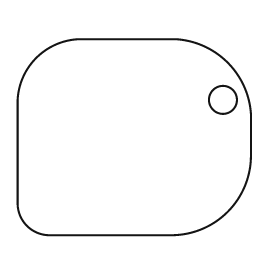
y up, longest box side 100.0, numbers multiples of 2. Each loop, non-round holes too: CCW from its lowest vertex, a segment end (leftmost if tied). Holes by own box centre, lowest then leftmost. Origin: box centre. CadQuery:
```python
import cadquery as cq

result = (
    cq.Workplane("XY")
    .moveTo(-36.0, -42.0)
    .lineTo(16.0, -42.0)
    .threePointArc((40.0, -32.0), (50.0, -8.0))
    .lineTo(50.0, 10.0)
    .threePointArc((40.0, 32.0), (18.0, 42.0))
    .lineTo(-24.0, 42.0)
    .threePointArc((-42.0, 34.0), (-50.0, 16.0))
    .lineTo(-50.0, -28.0)
    .threePointArc((-46.0, -38.0), (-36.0, -42.0))
    .close()
    .moveTo(38.0, 16.0)
    .circle(6.0)
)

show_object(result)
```